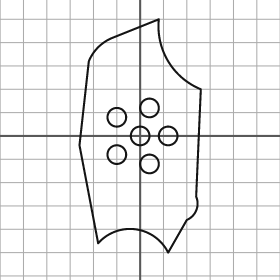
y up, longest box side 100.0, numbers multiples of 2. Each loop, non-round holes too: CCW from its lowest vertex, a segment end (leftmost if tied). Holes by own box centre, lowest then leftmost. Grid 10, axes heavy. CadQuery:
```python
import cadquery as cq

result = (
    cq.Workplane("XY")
    .moveTo(12.0, -50.0)
    .lineTo(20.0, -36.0)
    .threePointArc((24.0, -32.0), (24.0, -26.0))
    .lineTo(26.0, 20.0)
    .threePointArc((12.0, 32.0), (8.0, 50.0))
    .lineTo(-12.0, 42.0)
    .threePointArc((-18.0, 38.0), (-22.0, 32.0))
    .lineTo(-26.0, -4.0)
    .lineTo(-18.0, -46.0)
    .threePointArc((-2.0, -40.0), (12.0, -50.0))
    .close()
    .moveTo(4.0, -12.0)
    .circle(4.0)
    .moveTo(-10.0, -8.0)
    .circle(4.0)
    .moveTo(0.0, 0.0)
    .circle(4.0)
    .moveTo(12.0, 0.0)
    .circle(4.0)
    .moveTo(-10.0, 8.0)
    .circle(4.0)
    .moveTo(4.0, 12.0)
    .circle(4.0)
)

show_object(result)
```